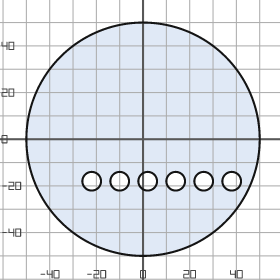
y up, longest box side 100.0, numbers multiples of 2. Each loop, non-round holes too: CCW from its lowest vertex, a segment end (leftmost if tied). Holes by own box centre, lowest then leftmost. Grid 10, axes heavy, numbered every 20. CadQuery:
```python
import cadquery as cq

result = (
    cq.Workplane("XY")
    .moveTo(0.0, 0.0)
    .circle(50.0)
    .moveTo(-22.0, -18.0)
    .circle(4.0)
    .moveTo(-10.0, -18.0)
    .circle(4.0)
    .moveTo(2.0, -18.0)
    .circle(4.0)
    .moveTo(14.0, -18.0)
    .circle(4.0)
    .moveTo(26.0, -18.0)
    .circle(4.0)
    .moveTo(38.0, -18.0)
    .circle(4.0)
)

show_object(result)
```